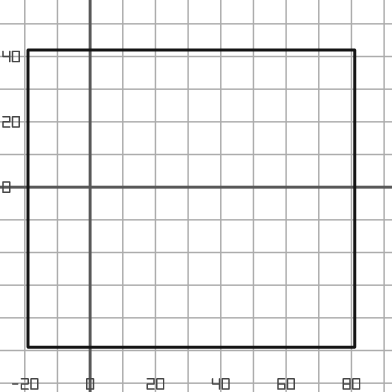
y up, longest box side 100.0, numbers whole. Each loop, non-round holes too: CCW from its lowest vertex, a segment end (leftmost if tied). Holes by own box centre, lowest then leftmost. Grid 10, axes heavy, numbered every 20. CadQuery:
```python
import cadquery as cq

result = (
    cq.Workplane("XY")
    .moveTo(-19.0, -49.0)
    .lineTo(81.0, -49.0)
    .lineTo(81.0, 42.0)
    .lineTo(-19.0, 42.0)
    .close()
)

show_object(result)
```